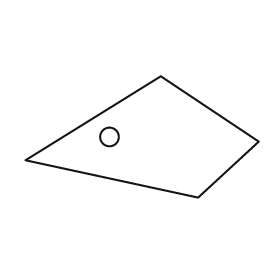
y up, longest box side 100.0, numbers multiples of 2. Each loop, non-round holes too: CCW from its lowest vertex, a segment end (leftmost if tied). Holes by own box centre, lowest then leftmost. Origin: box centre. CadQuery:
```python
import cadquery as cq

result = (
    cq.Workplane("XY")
    .moveTo(24.0, -26.0)
    .lineTo(50.0, -2.0)
    .lineTo(8.0, 26.0)
    .lineTo(-50.0, -10.0)
    .close()
    .moveTo(-14.0, 0.0)
    .circle(4.0)
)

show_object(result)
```